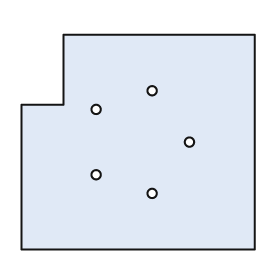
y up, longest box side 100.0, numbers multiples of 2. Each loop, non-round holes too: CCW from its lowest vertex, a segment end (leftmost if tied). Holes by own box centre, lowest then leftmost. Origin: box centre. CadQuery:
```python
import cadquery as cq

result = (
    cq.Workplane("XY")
    .moveTo(-50.0, -46.0)
    .lineTo(50.0, -46.0)
    .lineTo(50.0, 46.0)
    .lineTo(-32.0, 46.0)
    .lineTo(-32.0, 16.0)
    .lineTo(-50.0, 16.0)
    .close()
    .moveTo(6.0, -22.0)
    .circle(2.0)
    .moveTo(-18.0, -14.0)
    .circle(2.0)
    .moveTo(22.0, 0.0)
    .circle(2.0)
    .moveTo(-18.0, 14.0)
    .circle(2.0)
    .moveTo(6.0, 22.0)
    .circle(2.0)
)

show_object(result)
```